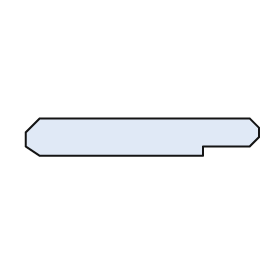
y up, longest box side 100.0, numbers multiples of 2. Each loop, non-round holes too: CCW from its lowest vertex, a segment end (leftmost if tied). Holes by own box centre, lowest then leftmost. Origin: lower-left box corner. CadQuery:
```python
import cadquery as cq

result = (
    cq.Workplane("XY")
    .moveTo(6.0, 0.0)
    .lineTo(76.0, 0.0)
    .lineTo(76.0, 4.0)
    .lineTo(96.0, 4.0)
    .lineTo(100.0, 8.0)
    .lineTo(100.0, 12.0)
    .lineTo(96.0, 16.0)
    .lineTo(6.0, 16.0)
    .lineTo(0.0, 10.0)
    .lineTo(0.0, 4.0)
    .close()
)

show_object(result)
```